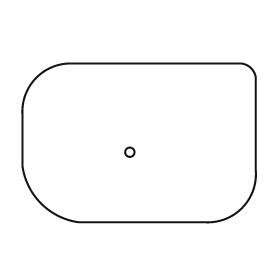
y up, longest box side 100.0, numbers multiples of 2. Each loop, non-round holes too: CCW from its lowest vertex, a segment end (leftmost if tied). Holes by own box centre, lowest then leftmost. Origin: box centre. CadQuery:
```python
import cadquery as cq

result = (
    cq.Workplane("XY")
    .moveTo(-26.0, -34.0)
    .lineTo(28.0, -34.0)
    .threePointArc((44.0, -28.0), (50.0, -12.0))
    .lineTo(50.0, 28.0)
    .threePointArc((48.0, 32.0), (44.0, 34.0))
    .lineTo(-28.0, 34.0)
    .threePointArc((-44.0, 28.0), (-50.0, 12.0))
    .lineTo(-50.0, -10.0)
    .threePointArc((-42.0, -26.0), (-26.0, -34.0))
    .close()
    .moveTo(-4.0, -4.0)
    .circle(2.0)
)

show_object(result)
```